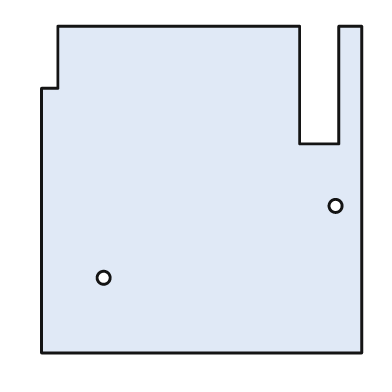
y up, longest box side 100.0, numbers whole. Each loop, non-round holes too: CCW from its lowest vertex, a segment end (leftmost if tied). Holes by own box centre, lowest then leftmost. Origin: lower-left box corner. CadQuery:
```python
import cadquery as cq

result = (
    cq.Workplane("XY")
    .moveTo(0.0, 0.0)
    .lineTo(98.0, 0.0)
    .lineTo(98.0, 100.0)
    .lineTo(91.0, 100.0)
    .lineTo(91.0, 64.0)
    .lineTo(79.0, 64.0)
    .lineTo(79.0, 100.0)
    .lineTo(5.0, 100.0)
    .lineTo(5.0, 81.0)
    .lineTo(0.0, 81.0)
    .close()
    .moveTo(19.0, 23.0)
    .circle(2.0)
    .moveTo(90.0, 45.0)
    .circle(2.0)
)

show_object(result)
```